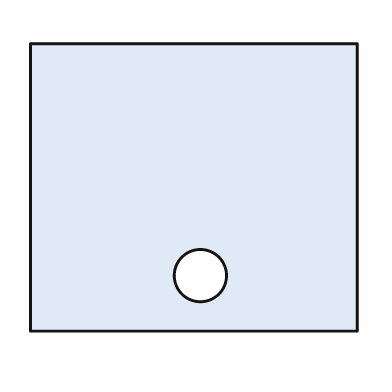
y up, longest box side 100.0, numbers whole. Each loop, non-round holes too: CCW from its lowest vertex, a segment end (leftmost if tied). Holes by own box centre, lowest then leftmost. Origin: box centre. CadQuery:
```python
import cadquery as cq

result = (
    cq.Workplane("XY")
    .moveTo(-50.0, -44.0)
    .lineTo(50.0, -44.0)
    .lineTo(50.0, 44.0)
    .lineTo(-50.0, 44.0)
    .close()
    .moveTo(2.0, -27.0)
    .circle(8.0)
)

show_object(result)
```